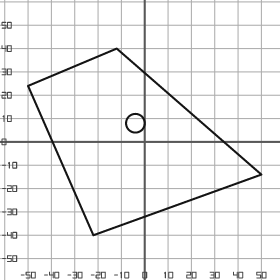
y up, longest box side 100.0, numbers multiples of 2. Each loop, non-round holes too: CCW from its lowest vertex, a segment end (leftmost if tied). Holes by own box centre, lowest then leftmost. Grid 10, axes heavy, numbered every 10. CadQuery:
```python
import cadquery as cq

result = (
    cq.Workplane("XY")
    .moveTo(-22.0, -40.0)
    .lineTo(50.0, -14.0)
    .lineTo(-12.0, 40.0)
    .lineTo(-50.0, 24.0)
    .close()
    .moveTo(-4.0, 8.0)
    .circle(4.0)
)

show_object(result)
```